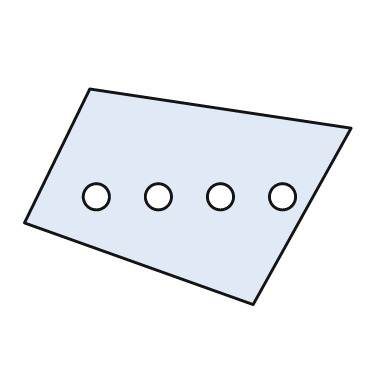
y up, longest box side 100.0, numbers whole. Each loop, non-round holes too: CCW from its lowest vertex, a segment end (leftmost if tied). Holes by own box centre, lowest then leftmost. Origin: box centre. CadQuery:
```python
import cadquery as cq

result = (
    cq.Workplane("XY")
    .moveTo(20.0, -33.0)
    .lineTo(50.0, 21.0)
    .lineTo(-30.0, 33.0)
    .lineTo(-50.0, -8.0)
    .close()
    .moveTo(-28.0, 0.0)
    .circle(4.0)
    .moveTo(-9.0, 0.0)
    .circle(4.0)
    .moveTo(10.0, 0.0)
    .circle(4.0)
    .moveTo(29.0, 0.0)
    .circle(4.0)
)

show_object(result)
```